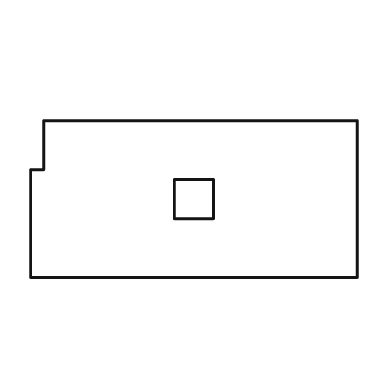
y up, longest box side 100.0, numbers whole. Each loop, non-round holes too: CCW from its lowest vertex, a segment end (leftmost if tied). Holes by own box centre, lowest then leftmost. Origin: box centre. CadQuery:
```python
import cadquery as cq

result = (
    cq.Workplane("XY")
    .moveTo(-50.0, -24.0)
    .lineTo(50.0, -24.0)
    .lineTo(50.0, 24.0)
    .lineTo(-46.0, 24.0)
    .lineTo(-46.0, 9.0)
    .lineTo(-50.0, 9.0)
    .close()
    .moveTo(-6.0, -6.0)
    .lineTo(6.0, -6.0)
    .lineTo(6.0, 6.0)
    .lineTo(-6.0, 6.0)
    .close()
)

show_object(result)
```